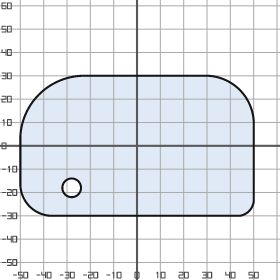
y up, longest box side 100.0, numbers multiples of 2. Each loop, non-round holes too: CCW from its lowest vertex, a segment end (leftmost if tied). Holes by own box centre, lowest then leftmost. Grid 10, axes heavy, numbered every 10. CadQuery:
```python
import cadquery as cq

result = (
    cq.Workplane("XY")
    .moveTo(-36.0, -30.0)
    .lineTo(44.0, -30.0)
    .threePointArc((48.0, -28.0), (50.0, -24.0))
    .lineTo(50.0, 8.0)
    .threePointArc((44.0, 24.0), (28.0, 30.0))
    .lineTo(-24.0, 30.0)
    .threePointArc((-42.0, 22.0), (-50.0, 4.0))
    .lineTo(-50.0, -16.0)
    .threePointArc((-46.0, -26.0), (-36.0, -30.0))
    .close()
    .moveTo(-28.0, -18.0)
    .circle(4.0)
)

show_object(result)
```